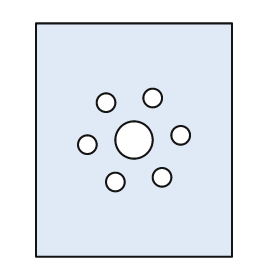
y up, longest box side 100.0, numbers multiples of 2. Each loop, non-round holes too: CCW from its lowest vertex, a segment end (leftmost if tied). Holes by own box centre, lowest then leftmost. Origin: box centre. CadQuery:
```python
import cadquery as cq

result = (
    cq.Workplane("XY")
    .moveTo(-42.0, -50.0)
    .lineTo(42.0, -50.0)
    .lineTo(42.0, 50.0)
    .lineTo(-42.0, 50.0)
    .close()
    .moveTo(-8.0, -18.0)
    .circle(4.0)
    .moveTo(12.0, -16.0)
    .circle(4.0)
    .moveTo(-20.0, -2.0)
    .circle(4.0)
    .moveTo(0.0, 0.0)
    .circle(8.0)
    .moveTo(20.0, 2.0)
    .circle(4.0)
    .moveTo(-12.0, 16.0)
    .circle(4.0)
    .moveTo(8.0, 18.0)
    .circle(4.0)
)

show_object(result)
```